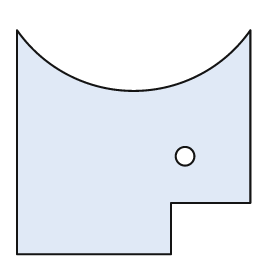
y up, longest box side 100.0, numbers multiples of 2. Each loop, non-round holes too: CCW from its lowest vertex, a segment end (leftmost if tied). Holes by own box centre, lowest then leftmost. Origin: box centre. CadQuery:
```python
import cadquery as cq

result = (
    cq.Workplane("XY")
    .moveTo(-50.0, -48.0)
    .lineTo(16.0, -48.0)
    .lineTo(16.0, -26.0)
    .lineTo(50.0, -26.0)
    .lineTo(50.0, 48.0)
    .threePointArc((0.0, 22.0), (-50.0, 48.0))
    .close()
    .moveTo(22.0, -6.0)
    .circle(4.0)
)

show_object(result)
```